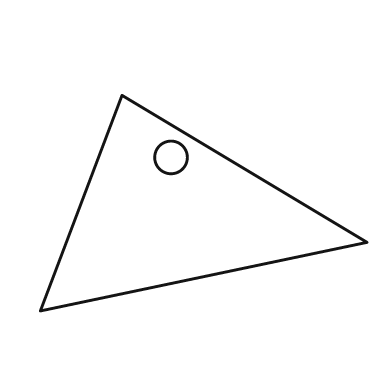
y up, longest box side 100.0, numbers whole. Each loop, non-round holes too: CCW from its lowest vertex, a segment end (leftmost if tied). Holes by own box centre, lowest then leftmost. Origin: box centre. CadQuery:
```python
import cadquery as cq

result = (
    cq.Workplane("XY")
    .moveTo(-50.0, -33.0)
    .lineTo(50.0, -12.0)
    .lineTo(-25.0, 33.0)
    .close()
    .moveTo(-10.0, 14.0)
    .circle(5.0)
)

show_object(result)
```